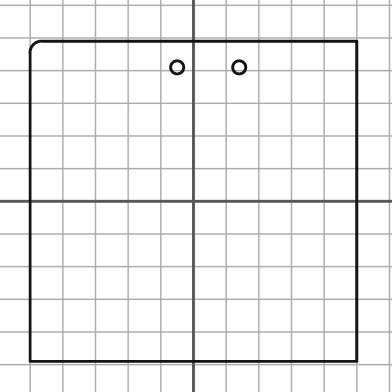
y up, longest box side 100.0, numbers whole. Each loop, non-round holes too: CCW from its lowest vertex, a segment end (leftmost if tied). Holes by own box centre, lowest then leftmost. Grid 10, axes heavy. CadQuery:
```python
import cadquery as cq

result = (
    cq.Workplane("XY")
    .moveTo(-50.0, -49.0)
    .lineTo(50.0, -49.0)
    .lineTo(50.0, 49.0)
    .lineTo(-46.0, 49.0)
    .threePointArc((-49.0, 48.0), (-50.0, 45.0))
    .close()
    .moveTo(-5.0, 41.0)
    .circle(2.0)
    .moveTo(14.0, 41.0)
    .circle(2.0)
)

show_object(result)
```